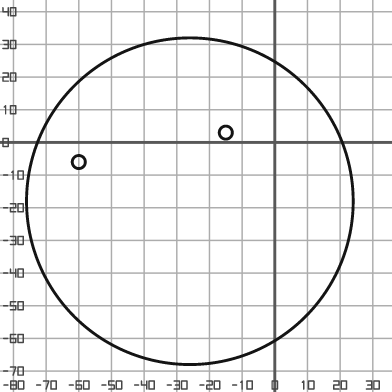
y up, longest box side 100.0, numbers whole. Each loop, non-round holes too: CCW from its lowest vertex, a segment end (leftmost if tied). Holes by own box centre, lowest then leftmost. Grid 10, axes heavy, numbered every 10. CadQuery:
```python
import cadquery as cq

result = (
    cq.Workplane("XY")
    .moveTo(-26.0, -18.0)
    .circle(50.0)
    .moveTo(-60.0, -6.0)
    .circle(2.0)
    .moveTo(-15.0, 3.0)
    .circle(2.0)
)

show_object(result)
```